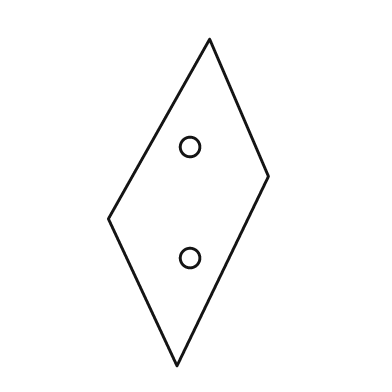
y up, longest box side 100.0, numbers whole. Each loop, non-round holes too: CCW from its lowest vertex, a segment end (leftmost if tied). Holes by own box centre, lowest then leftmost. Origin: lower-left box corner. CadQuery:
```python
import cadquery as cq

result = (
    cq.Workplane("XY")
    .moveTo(21.0, 0.0)
    .lineTo(49.0, 58.0)
    .lineTo(31.0, 100.0)
    .lineTo(0.0, 45.0)
    .close()
    .moveTo(25.0, 33.0)
    .circle(3.0)
    .moveTo(25.0, 67.0)
    .circle(3.0)
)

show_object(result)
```